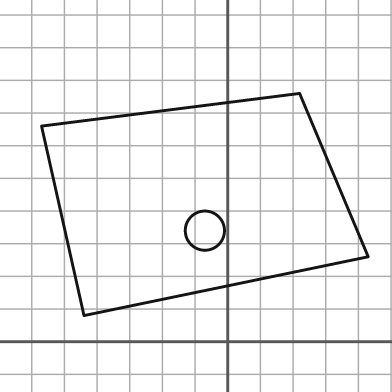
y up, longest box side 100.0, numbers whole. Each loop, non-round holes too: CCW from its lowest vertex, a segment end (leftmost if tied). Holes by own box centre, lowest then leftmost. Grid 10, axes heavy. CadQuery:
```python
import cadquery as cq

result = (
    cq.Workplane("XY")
    .moveTo(-44.0, 8.0)
    .lineTo(43.0, 26.0)
    .lineTo(22.0, 76.0)
    .lineTo(-57.0, 66.0)
    .close()
    .moveTo(-7.0, 34.0)
    .circle(6.0)
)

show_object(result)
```